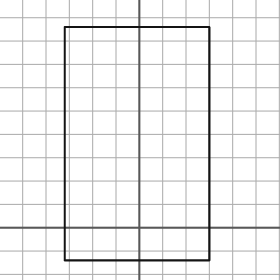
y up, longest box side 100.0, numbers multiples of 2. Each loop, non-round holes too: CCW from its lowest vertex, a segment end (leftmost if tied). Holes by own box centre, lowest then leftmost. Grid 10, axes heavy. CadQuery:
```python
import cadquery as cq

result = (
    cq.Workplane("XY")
    .moveTo(-32.0, -14.0)
    .lineTo(30.0, -14.0)
    .lineTo(30.0, 86.0)
    .lineTo(-32.0, 86.0)
    .close()
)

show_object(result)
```